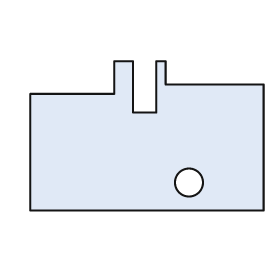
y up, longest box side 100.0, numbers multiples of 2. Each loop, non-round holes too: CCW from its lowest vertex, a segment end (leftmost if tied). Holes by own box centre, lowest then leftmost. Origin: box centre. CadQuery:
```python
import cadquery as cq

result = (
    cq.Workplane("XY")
    .moveTo(-50.0, -32.0)
    .lineTo(50.0, -32.0)
    .lineTo(50.0, 22.0)
    .lineTo(8.0, 22.0)
    .lineTo(8.0, 32.0)
    .lineTo(4.0, 32.0)
    .lineTo(4.0, 10.0)
    .lineTo(-6.0, 10.0)
    .lineTo(-6.0, 32.0)
    .lineTo(-14.0, 32.0)
    .lineTo(-14.0, 18.0)
    .lineTo(-50.0, 18.0)
    .close()
    .moveTo(18.0, -20.0)
    .circle(6.0)
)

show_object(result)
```